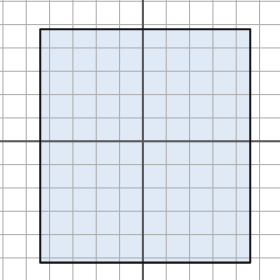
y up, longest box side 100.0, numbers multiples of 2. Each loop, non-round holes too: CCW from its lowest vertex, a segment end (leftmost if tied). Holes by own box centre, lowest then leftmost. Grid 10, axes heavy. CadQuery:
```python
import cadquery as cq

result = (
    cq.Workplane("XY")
    .moveTo(-44.0, -52.0)
    .lineTo(46.0, -52.0)
    .lineTo(46.0, 48.0)
    .lineTo(-44.0, 48.0)
    .close()
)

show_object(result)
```